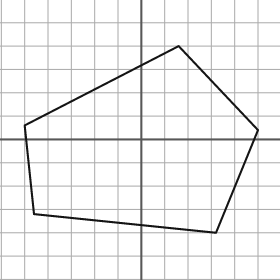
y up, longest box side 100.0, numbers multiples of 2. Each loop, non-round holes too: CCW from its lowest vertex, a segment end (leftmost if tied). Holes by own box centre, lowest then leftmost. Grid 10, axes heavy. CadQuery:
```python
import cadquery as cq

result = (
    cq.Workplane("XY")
    .moveTo(32.0, -40.0)
    .lineTo(50.0, 4.0)
    .lineTo(16.0, 40.0)
    .lineTo(-50.0, 6.0)
    .lineTo(-46.0, -32.0)
    .close()
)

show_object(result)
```